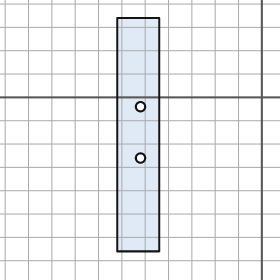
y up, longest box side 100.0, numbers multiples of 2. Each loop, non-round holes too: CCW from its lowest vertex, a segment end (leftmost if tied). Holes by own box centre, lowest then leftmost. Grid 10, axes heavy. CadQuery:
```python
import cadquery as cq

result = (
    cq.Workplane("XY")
    .moveTo(-62.0, -66.0)
    .lineTo(-44.0, -66.0)
    .lineTo(-44.0, 34.0)
    .lineTo(-62.0, 34.0)
    .close()
    .moveTo(-52.0, -26.0)
    .circle(2.0)
    .moveTo(-52.0, -4.0)
    .circle(2.0)
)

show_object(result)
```